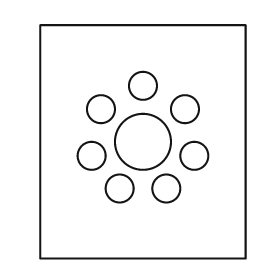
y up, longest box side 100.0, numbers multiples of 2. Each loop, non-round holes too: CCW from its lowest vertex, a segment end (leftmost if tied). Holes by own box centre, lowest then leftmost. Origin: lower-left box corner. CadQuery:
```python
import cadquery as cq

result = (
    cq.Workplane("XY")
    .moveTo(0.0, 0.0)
    .lineTo(88.0, 0.0)
    .lineTo(88.0, 100.0)
    .lineTo(0.0, 100.0)
    .close()
    .moveTo(34.0, 30.0)
    .circle(6.0)
    .moveTo(54.0, 30.0)
    .circle(6.0)
    .moveTo(22.0, 44.0)
    .circle(6.0)
    .moveTo(66.0, 44.0)
    .circle(6.0)
    .moveTo(44.0, 50.0)
    .circle(12.0)
    .moveTo(26.0, 64.0)
    .circle(6.0)
    .moveTo(62.0, 64.0)
    .circle(6.0)
    .moveTo(44.0, 74.0)
    .circle(6.0)
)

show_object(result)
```